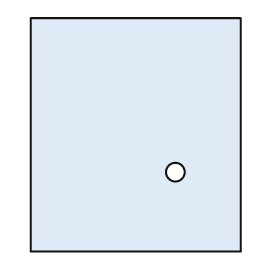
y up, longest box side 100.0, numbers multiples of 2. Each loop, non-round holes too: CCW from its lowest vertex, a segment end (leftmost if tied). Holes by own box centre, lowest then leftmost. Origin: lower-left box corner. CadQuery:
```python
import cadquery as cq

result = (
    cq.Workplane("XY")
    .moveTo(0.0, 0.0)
    .lineTo(90.0, 0.0)
    .lineTo(90.0, 100.0)
    .lineTo(0.0, 100.0)
    .close()
    .moveTo(62.0, 34.0)
    .circle(4.0)
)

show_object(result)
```